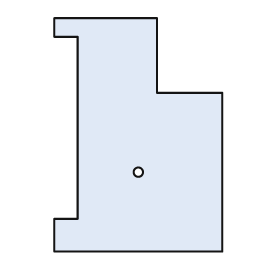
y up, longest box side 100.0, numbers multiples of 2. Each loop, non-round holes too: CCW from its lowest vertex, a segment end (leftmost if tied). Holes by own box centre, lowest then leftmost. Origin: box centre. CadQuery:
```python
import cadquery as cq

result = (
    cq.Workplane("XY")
    .moveTo(-36.0, -50.0)
    .lineTo(36.0, -50.0)
    .lineTo(36.0, 18.0)
    .lineTo(8.0, 18.0)
    .lineTo(8.0, 50.0)
    .lineTo(-36.0, 50.0)
    .lineTo(-36.0, 42.0)
    .lineTo(-26.0, 42.0)
    .lineTo(-26.0, -36.0)
    .lineTo(-36.0, -36.0)
    .close()
    .moveTo(0.0, -16.0)
    .circle(2.0)
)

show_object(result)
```